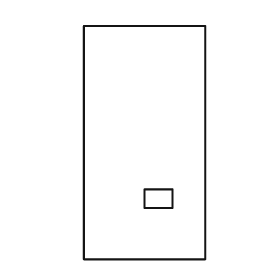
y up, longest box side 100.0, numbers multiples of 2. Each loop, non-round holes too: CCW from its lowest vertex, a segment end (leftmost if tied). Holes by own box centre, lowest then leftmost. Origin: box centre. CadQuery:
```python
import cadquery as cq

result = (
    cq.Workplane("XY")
    .moveTo(-26.0, -50.0)
    .lineTo(26.0, -50.0)
    .lineTo(26.0, 50.0)
    .lineTo(-26.0, 50.0)
    .close()
    .moveTo(0.0, -28.0)
    .lineTo(12.0, -28.0)
    .lineTo(12.0, -20.0)
    .lineTo(0.0, -20.0)
    .close()
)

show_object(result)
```